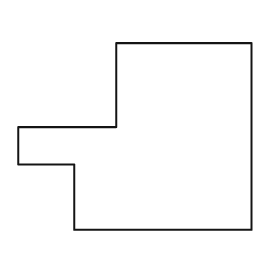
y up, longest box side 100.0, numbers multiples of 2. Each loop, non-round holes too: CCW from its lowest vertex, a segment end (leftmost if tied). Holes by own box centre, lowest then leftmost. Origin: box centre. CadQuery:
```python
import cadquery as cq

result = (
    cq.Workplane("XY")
    .moveTo(-26.0, -40.0)
    .lineTo(50.0, -40.0)
    .lineTo(50.0, 40.0)
    .lineTo(-8.0, 40.0)
    .lineTo(-8.0, 4.0)
    .lineTo(-50.0, 4.0)
    .lineTo(-50.0, -12.0)
    .lineTo(-26.0, -12.0)
    .close()
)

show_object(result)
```